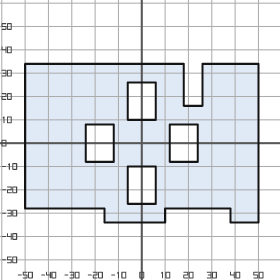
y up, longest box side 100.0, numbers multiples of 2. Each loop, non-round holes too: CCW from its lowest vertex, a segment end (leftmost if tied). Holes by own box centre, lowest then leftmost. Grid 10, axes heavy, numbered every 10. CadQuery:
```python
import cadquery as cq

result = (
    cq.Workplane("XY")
    .moveTo(-16.0, -34.0)
    .lineTo(10.0, -34.0)
    .lineTo(10.0, -28.0)
    .lineTo(38.0, -28.0)
    .lineTo(38.0, -34.0)
    .lineTo(50.0, -34.0)
    .lineTo(50.0, 34.0)
    .lineTo(26.0, 34.0)
    .lineTo(26.0, 16.0)
    .lineTo(18.0, 16.0)
    .lineTo(18.0, 34.0)
    .lineTo(-50.0, 34.0)
    .lineTo(-50.0, -28.0)
    .lineTo(-16.0, -28.0)
    .close()
    .moveTo(-6.0, -26.0)
    .lineTo(6.0, -26.0)
    .lineTo(6.0, -10.0)
    .lineTo(-6.0, -10.0)
    .close()
    .moveTo(-24.0, -8.0)
    .lineTo(-12.0, -8.0)
    .lineTo(-12.0, 8.0)
    .lineTo(-24.0, 8.0)
    .close()
    .moveTo(12.0, -8.0)
    .lineTo(24.0, -8.0)
    .lineTo(24.0, 8.0)
    .lineTo(12.0, 8.0)
    .close()
    .moveTo(-6.0, 10.0)
    .lineTo(6.0, 10.0)
    .lineTo(6.0, 26.0)
    .lineTo(-6.0, 26.0)
    .close()
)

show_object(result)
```